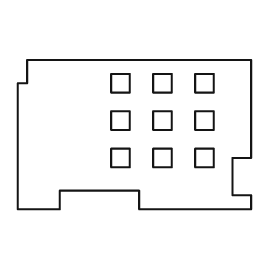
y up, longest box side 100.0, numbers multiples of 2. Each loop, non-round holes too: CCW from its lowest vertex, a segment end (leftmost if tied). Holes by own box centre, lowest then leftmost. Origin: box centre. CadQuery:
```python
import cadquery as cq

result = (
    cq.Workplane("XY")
    .moveTo(-50.0, -32.0)
    .lineTo(-32.0, -32.0)
    .lineTo(-32.0, -24.0)
    .lineTo(2.0, -24.0)
    .lineTo(2.0, -32.0)
    .lineTo(50.0, -32.0)
    .lineTo(50.0, -26.0)
    .lineTo(42.0, -26.0)
    .lineTo(42.0, -10.0)
    .lineTo(50.0, -10.0)
    .lineTo(50.0, 32.0)
    .lineTo(-46.0, 32.0)
    .lineTo(-46.0, 22.0)
    .lineTo(-50.0, 22.0)
    .close()
    .moveTo(-10.0, -14.0)
    .lineTo(-2.0, -14.0)
    .lineTo(-2.0, -6.0)
    .lineTo(-10.0, -6.0)
    .close()
    .moveTo(8.0, -14.0)
    .lineTo(16.0, -14.0)
    .lineTo(16.0, -6.0)
    .lineTo(8.0, -6.0)
    .close()
    .moveTo(26.0, -14.0)
    .lineTo(34.0, -14.0)
    .lineTo(34.0, -6.0)
    .lineTo(26.0, -6.0)
    .close()
    .moveTo(-10.0, 2.0)
    .lineTo(-2.0, 2.0)
    .lineTo(-2.0, 10.0)
    .lineTo(-10.0, 10.0)
    .close()
    .moveTo(8.0, 2.0)
    .lineTo(16.0, 2.0)
    .lineTo(16.0, 10.0)
    .lineTo(8.0, 10.0)
    .close()
    .moveTo(26.0, 2.0)
    .lineTo(34.0, 2.0)
    .lineTo(34.0, 10.0)
    .lineTo(26.0, 10.0)
    .close()
    .moveTo(-10.0, 18.0)
    .lineTo(-2.0, 18.0)
    .lineTo(-2.0, 26.0)
    .lineTo(-10.0, 26.0)
    .close()
    .moveTo(8.0, 18.0)
    .lineTo(16.0, 18.0)
    .lineTo(16.0, 26.0)
    .lineTo(8.0, 26.0)
    .close()
    .moveTo(26.0, 18.0)
    .lineTo(34.0, 18.0)
    .lineTo(34.0, 26.0)
    .lineTo(26.0, 26.0)
    .close()
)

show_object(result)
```